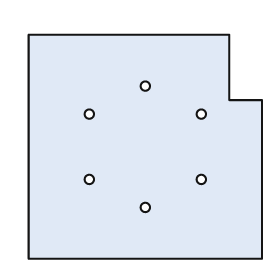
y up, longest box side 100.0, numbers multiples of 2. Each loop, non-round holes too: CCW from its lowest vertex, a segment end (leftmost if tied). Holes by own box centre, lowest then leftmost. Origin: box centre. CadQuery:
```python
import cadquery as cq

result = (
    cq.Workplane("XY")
    .moveTo(-50.0, -48.0)
    .lineTo(50.0, -48.0)
    .lineTo(50.0, 20.0)
    .lineTo(36.0, 20.0)
    .lineTo(36.0, 48.0)
    .lineTo(-50.0, 48.0)
    .close()
    .moveTo(0.0, -26.0)
    .circle(2.0)
    .moveTo(-24.0, -14.0)
    .circle(2.0)
    .moveTo(24.0, -14.0)
    .circle(2.0)
    .moveTo(-24.0, 14.0)
    .circle(2.0)
    .moveTo(24.0, 14.0)
    .circle(2.0)
    .moveTo(0.0, 26.0)
    .circle(2.0)
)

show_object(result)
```